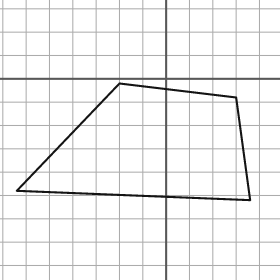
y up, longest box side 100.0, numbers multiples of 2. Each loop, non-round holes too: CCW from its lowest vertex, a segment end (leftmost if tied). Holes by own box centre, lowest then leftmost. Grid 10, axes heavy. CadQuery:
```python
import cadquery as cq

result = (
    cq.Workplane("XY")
    .moveTo(36.0, -52.0)
    .lineTo(30.0, -8.0)
    .lineTo(-20.0, -2.0)
    .lineTo(-64.0, -48.0)
    .close()
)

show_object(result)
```